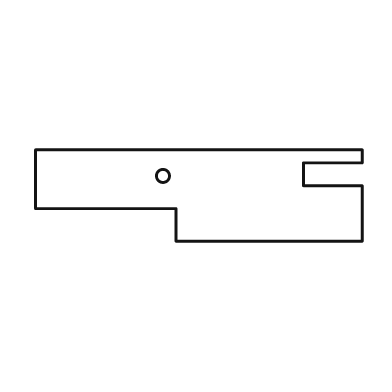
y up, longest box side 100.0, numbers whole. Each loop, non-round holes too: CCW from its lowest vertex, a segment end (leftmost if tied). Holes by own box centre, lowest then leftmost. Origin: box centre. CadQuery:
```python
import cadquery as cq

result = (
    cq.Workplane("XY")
    .moveTo(-7.0, -14.0)
    .lineTo(50.0, -14.0)
    .lineTo(50.0, 3.0)
    .lineTo(32.0, 3.0)
    .lineTo(32.0, 10.0)
    .lineTo(50.0, 10.0)
    .lineTo(50.0, 14.0)
    .lineTo(-50.0, 14.0)
    .lineTo(-50.0, -4.0)
    .lineTo(-7.0, -4.0)
    .close()
    .moveTo(-11.0, 6.0)
    .circle(2.0)
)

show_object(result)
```